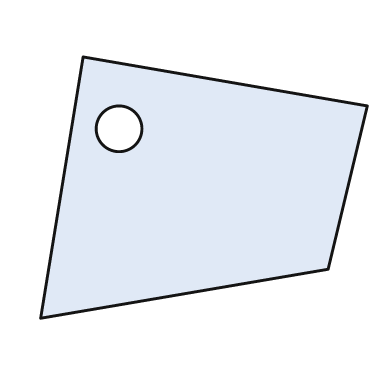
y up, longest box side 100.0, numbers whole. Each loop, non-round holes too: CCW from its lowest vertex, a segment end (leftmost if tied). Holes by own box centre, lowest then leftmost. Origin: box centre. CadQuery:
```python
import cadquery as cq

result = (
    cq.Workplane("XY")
    .moveTo(-50.0, -40.0)
    .lineTo(38.0, -25.0)
    .lineTo(50.0, 25.0)
    .lineTo(-37.0, 40.0)
    .close()
    .moveTo(-26.0, 18.0)
    .circle(7.0)
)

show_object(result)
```